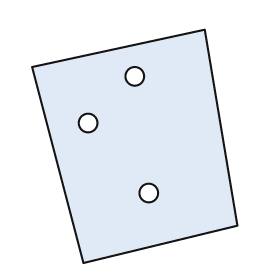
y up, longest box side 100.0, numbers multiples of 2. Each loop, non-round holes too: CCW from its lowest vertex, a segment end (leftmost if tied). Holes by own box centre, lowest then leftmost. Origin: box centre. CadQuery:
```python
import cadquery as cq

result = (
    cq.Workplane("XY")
    .moveTo(-22.0, -50.0)
    .lineTo(44.0, -34.0)
    .lineTo(30.0, 50.0)
    .lineTo(-44.0, 34.0)
    .close()
    .moveTo(6.0, -20.0)
    .circle(4.0)
    .moveTo(-20.0, 10.0)
    .circle(4.0)
    .moveTo(0.0, 30.0)
    .circle(4.0)
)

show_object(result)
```